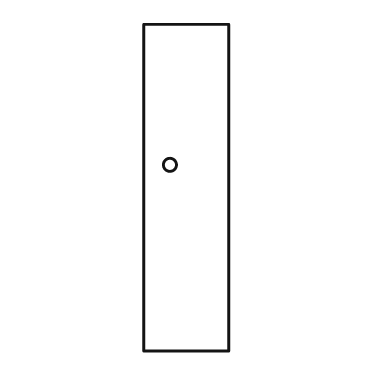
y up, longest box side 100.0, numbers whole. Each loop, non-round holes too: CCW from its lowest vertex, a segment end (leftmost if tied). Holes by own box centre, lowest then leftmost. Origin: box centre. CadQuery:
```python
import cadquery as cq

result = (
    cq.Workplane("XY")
    .moveTo(-13.0, -50.0)
    .lineTo(13.0, -50.0)
    .lineTo(13.0, 50.0)
    .lineTo(-13.0, 50.0)
    .close()
    .moveTo(-5.0, 7.0)
    .circle(2.0)
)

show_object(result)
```